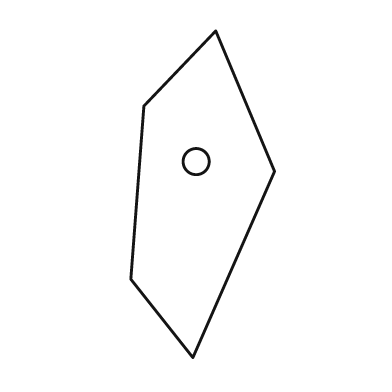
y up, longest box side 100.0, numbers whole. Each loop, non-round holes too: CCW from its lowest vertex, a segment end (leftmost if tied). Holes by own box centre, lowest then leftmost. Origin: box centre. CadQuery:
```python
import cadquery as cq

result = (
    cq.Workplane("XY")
    .moveTo(-3.0, -50.0)
    .lineTo(22.0, 7.0)
    .lineTo(4.0, 50.0)
    .lineTo(-18.0, 27.0)
    .lineTo(-22.0, -26.0)
    .close()
    .moveTo(-2.0, 10.0)
    .circle(4.0)
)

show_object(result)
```